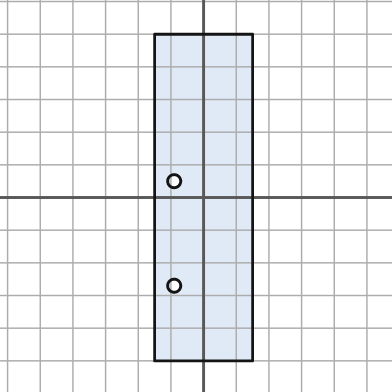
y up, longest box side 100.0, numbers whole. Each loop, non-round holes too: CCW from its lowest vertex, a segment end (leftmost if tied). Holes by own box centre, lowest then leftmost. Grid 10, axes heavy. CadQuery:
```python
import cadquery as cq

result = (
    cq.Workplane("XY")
    .moveTo(-15.0, -50.0)
    .lineTo(15.0, -50.0)
    .lineTo(15.0, 50.0)
    .lineTo(-15.0, 50.0)
    .close()
    .moveTo(-9.0, -27.0)
    .circle(2.0)
    .moveTo(-9.0, 5.0)
    .circle(2.0)
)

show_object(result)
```